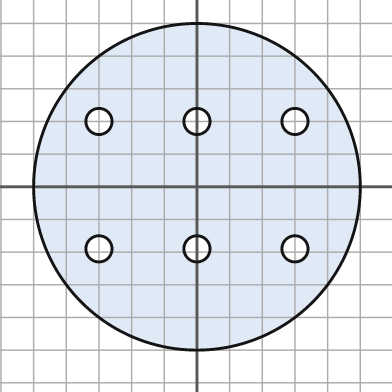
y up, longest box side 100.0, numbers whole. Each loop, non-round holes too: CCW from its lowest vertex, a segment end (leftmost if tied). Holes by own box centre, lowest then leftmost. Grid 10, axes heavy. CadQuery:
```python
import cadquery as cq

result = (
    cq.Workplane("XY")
    .moveTo(0.0, 0.0)
    .circle(50.0)
    .moveTo(-30.0, -19.0)
    .circle(4.0)
    .moveTo(0.0, -19.0)
    .circle(4.0)
    .moveTo(30.0, -19.0)
    .circle(4.0)
    .moveTo(-30.0, 20.0)
    .circle(4.0)
    .moveTo(0.0, 20.0)
    .circle(4.0)
    .moveTo(30.0, 20.0)
    .circle(4.0)
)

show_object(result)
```